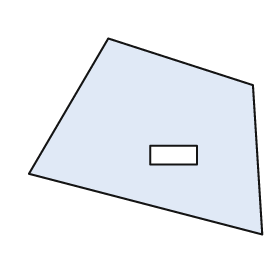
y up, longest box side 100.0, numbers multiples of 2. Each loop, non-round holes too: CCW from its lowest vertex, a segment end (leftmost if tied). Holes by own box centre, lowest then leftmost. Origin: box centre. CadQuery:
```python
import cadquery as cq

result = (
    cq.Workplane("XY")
    .moveTo(50.0, -42.0)
    .lineTo(46.0, 22.0)
    .lineTo(-16.0, 42.0)
    .lineTo(-50.0, -16.0)
    .close()
    .moveTo(2.0, -12.0)
    .lineTo(22.0, -12.0)
    .lineTo(22.0, -4.0)
    .lineTo(2.0, -4.0)
    .close()
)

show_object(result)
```